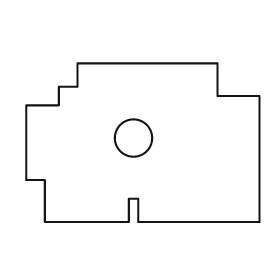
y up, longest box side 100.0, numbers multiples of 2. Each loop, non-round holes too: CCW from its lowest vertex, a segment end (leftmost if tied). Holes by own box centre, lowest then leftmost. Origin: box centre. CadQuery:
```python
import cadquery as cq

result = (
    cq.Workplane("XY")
    .moveTo(-42.0, -34.0)
    .lineTo(-6.0, -34.0)
    .lineTo(-6.0, -24.0)
    .lineTo(-2.0, -24.0)
    .lineTo(-2.0, -34.0)
    .lineTo(50.0, -34.0)
    .lineTo(50.0, 20.0)
    .lineTo(32.0, 20.0)
    .lineTo(32.0, 34.0)
    .lineTo(-28.0, 34.0)
    .lineTo(-28.0, 24.0)
    .lineTo(-36.0, 24.0)
    .lineTo(-36.0, 16.0)
    .lineTo(-50.0, 16.0)
    .lineTo(-50.0, -16.0)
    .lineTo(-42.0, -16.0)
    .close()
    .moveTo(-4.0, 2.0)
    .circle(8.0)
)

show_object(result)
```